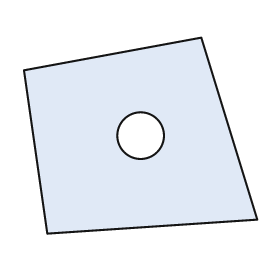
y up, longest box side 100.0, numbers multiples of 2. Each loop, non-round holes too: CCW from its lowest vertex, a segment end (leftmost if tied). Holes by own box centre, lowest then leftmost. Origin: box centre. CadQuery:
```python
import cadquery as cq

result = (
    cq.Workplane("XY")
    .moveTo(-40.0, -42.0)
    .lineTo(50.0, -36.0)
    .lineTo(26.0, 42.0)
    .lineTo(-50.0, 28.0)
    .close()
    .moveTo(0.0, 0.0)
    .circle(10.0)
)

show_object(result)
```